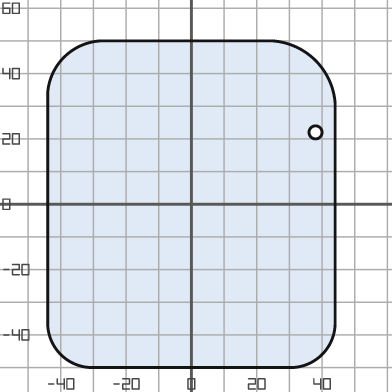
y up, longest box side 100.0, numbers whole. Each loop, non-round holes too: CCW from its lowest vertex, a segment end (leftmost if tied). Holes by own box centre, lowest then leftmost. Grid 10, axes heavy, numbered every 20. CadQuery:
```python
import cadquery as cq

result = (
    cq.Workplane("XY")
    .moveTo(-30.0, -50.0)
    .lineTo(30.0, -50.0)
    .threePointArc((40.0, -46.0), (44.0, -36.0))
    .lineTo(44.0, 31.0)
    .threePointArc((38.0, 44.0), (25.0, 50.0))
    .lineTo(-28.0, 50.0)
    .threePointArc((-39.0, 45.0), (-44.0, 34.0))
    .lineTo(-44.0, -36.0)
    .threePointArc((-40.0, -46.0), (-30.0, -50.0))
    .close()
    .moveTo(38.0, 22.0)
    .circle(2.0)
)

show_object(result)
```